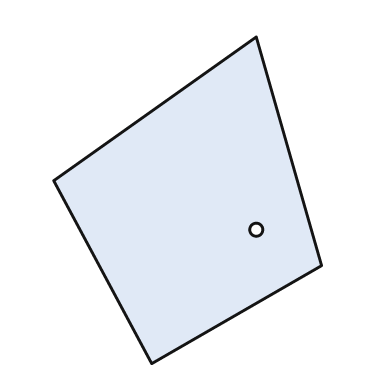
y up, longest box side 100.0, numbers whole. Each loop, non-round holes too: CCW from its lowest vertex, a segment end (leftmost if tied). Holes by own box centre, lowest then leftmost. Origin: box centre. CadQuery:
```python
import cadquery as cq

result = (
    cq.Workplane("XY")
    .moveTo(-11.0, -50.0)
    .lineTo(41.0, -20.0)
    .lineTo(21.0, 50.0)
    .lineTo(-41.0, 6.0)
    .close()
    .moveTo(21.0, -9.0)
    .circle(2.0)
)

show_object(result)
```